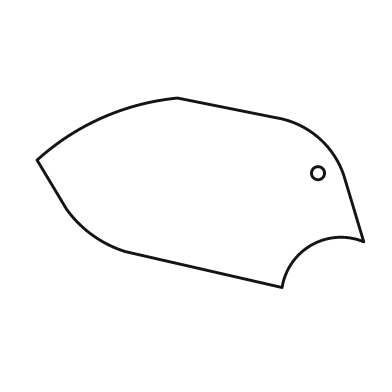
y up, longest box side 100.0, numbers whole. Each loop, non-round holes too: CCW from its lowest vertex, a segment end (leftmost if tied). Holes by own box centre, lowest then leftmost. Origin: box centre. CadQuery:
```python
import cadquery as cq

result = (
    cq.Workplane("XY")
    .moveTo(25.0, -29.0)
    .threePointArc((34.0, -16.0), (50.0, -15.0))
    .lineTo(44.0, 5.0)
    .threePointArc((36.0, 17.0), (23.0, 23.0))
    .lineTo(-7.0, 29.0)
    .threePointArc((-30.0, 23.0), (-50.0, 10.0))
    .lineTo(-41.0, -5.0)
    .threePointArc((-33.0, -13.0), (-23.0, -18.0))
    .close()
    .moveTo(36.0, 6.0)
    .circle(2.0)
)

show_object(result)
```